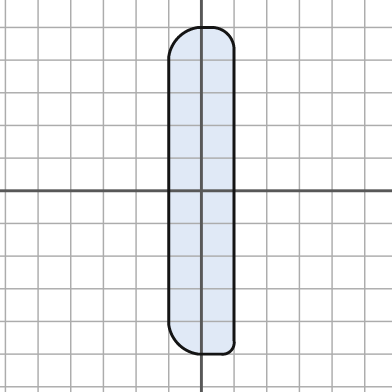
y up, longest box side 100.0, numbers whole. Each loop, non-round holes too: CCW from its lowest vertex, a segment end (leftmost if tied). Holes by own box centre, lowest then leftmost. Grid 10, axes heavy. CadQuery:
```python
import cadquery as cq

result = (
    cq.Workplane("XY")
    .moveTo(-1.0, -50.0)
    .lineTo(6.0, -50.0)
    .threePointArc((9.0, -49.0), (10.0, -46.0))
    .lineTo(10.0, 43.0)
    .threePointArc((8.0, 48.0), (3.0, 50.0))
    .lineTo(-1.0, 50.0)
    .threePointArc((-7.0, 47.0), (-10.0, 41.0))
    .lineTo(-10.0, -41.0)
    .threePointArc((-7.0, -47.0), (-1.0, -50.0))
    .close()
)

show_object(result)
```